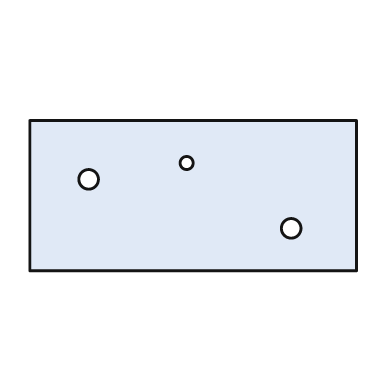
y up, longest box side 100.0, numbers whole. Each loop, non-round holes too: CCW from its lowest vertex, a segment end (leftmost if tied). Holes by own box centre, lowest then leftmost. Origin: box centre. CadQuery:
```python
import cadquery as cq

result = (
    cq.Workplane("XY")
    .moveTo(-50.0, -23.0)
    .lineTo(50.0, -23.0)
    .lineTo(50.0, 23.0)
    .lineTo(-50.0, 23.0)
    .close()
    .moveTo(30.0, -10.0)
    .circle(3.0)
    .moveTo(-32.0, 5.0)
    .circle(3.0)
    .moveTo(-2.0, 10.0)
    .circle(2.0)
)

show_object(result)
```